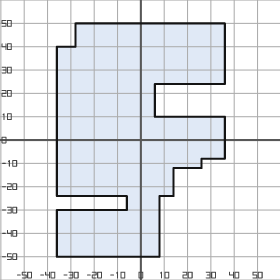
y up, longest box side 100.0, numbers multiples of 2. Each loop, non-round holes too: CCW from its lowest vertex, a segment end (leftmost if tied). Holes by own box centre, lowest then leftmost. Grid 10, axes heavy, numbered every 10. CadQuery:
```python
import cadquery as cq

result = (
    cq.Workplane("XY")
    .moveTo(-36.0, -50.0)
    .lineTo(8.0, -50.0)
    .lineTo(8.0, -24.0)
    .lineTo(14.0, -24.0)
    .lineTo(14.0, -12.0)
    .lineTo(26.0, -12.0)
    .lineTo(26.0, -8.0)
    .lineTo(36.0, -8.0)
    .lineTo(36.0, 10.0)
    .lineTo(6.0, 10.0)
    .lineTo(6.0, 24.0)
    .lineTo(36.0, 24.0)
    .lineTo(36.0, 50.0)
    .lineTo(-28.0, 50.0)
    .lineTo(-28.0, 40.0)
    .lineTo(-36.0, 40.0)
    .lineTo(-36.0, -24.0)
    .lineTo(-6.0, -24.0)
    .lineTo(-6.0, -30.0)
    .lineTo(-36.0, -30.0)
    .close()
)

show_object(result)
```